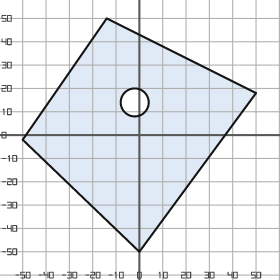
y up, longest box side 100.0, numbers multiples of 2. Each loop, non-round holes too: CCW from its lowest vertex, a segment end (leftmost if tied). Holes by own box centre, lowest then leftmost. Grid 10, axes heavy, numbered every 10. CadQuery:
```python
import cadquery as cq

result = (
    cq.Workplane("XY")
    .moveTo(0.0, -50.0)
    .lineTo(50.0, 18.0)
    .lineTo(-14.0, 50.0)
    .lineTo(-50.0, -2.0)
    .close()
    .moveTo(-2.0, 14.0)
    .circle(6.0)
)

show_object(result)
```